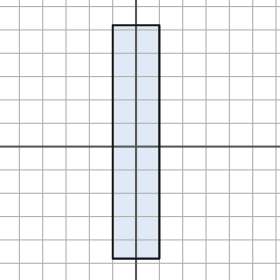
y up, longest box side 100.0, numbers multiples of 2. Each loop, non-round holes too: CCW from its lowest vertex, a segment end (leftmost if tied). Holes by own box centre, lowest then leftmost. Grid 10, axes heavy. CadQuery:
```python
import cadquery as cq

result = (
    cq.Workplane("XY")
    .moveTo(-10.0, -48.0)
    .lineTo(10.0, -48.0)
    .lineTo(10.0, 52.0)
    .lineTo(-10.0, 52.0)
    .close()
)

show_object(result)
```